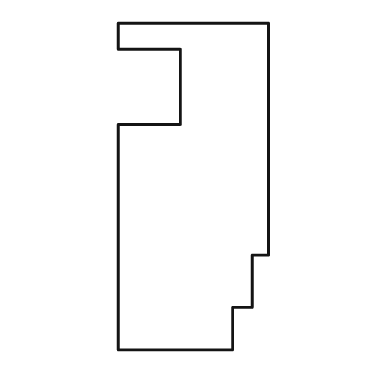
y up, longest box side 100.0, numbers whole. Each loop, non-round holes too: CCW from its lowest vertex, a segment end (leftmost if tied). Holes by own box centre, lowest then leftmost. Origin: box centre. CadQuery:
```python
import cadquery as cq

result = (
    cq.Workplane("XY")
    .moveTo(-23.0, -50.0)
    .lineTo(12.0, -50.0)
    .lineTo(12.0, -37.0)
    .lineTo(18.0, -37.0)
    .lineTo(18.0, -21.0)
    .lineTo(23.0, -21.0)
    .lineTo(23.0, 50.0)
    .lineTo(-23.0, 50.0)
    .lineTo(-23.0, 42.0)
    .lineTo(-4.0, 42.0)
    .lineTo(-4.0, 19.0)
    .lineTo(-23.0, 19.0)
    .close()
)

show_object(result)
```